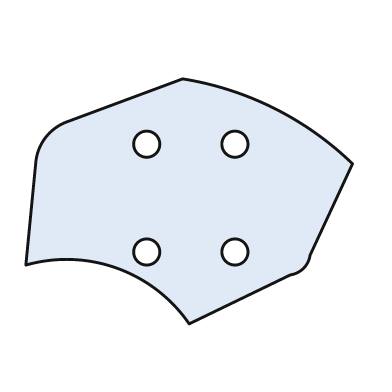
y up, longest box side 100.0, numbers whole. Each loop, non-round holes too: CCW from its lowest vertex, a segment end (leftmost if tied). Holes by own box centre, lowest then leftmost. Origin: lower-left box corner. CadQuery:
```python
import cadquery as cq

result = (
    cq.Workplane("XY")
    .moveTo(50.0, 0.0)
    .lineTo(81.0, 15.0)
    .threePointArc((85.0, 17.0), (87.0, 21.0))
    .lineTo(100.0, 49.0)
    .threePointArc((76.0, 66.0), (48.0, 75.0))
    .lineTo(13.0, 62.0)
    .threePointArc((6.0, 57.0), (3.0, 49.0))
    .lineTo(0.0, 18.0)
    .threePointArc((28.0, 17.0), (50.0, 0.0))
    .close()
    .moveTo(37.0, 22.0)
    .circle(4.0)
    .moveTo(64.0, 22.0)
    .circle(4.0)
    .moveTo(37.0, 55.0)
    .circle(4.0)
    .moveTo(64.0, 55.0)
    .circle(4.0)
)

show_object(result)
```